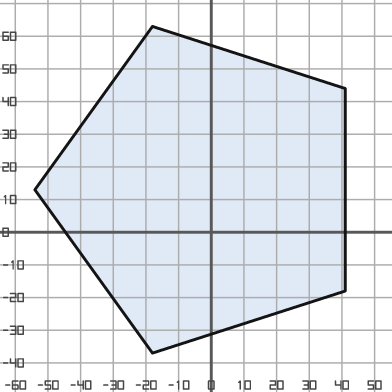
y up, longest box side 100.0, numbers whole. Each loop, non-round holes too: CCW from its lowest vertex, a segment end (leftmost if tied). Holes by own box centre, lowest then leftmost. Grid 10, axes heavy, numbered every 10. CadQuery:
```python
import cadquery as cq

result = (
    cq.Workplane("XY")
    .moveTo(-18.0, -37.0)
    .lineTo(41.0, -18.0)
    .lineTo(41.0, 44.0)
    .lineTo(-18.0, 63.0)
    .lineTo(-54.0, 13.0)
    .close()
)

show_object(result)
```